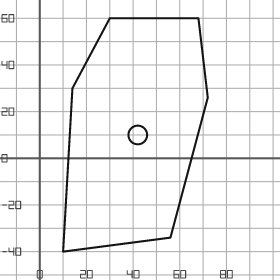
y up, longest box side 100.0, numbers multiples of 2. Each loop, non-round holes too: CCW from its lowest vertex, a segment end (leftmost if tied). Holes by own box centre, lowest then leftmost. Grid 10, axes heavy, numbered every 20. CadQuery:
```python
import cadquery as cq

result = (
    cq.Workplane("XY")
    .moveTo(10.0, -40.0)
    .lineTo(56.0, -34.0)
    .lineTo(72.0, 26.0)
    .lineTo(68.0, 60.0)
    .lineTo(30.0, 60.0)
    .lineTo(14.0, 30.0)
    .close()
    .moveTo(42.0, 10.0)
    .circle(4.0)
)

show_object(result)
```